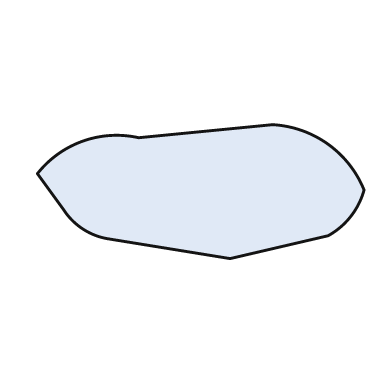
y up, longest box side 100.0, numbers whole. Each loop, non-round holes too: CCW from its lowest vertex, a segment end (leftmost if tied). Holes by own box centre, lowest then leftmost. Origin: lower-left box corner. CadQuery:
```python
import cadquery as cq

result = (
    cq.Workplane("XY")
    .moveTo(59.0, 0.0)
    .lineTo(89.0, 7.0)
    .threePointArc((96.0, 13.0), (100.0, 21.0))
    .threePointArc((89.0, 35.0), (72.0, 41.0))
    .lineTo(31.0, 37.0)
    .threePointArc((14.0, 36.0), (0.0, 26.0))
    .lineTo(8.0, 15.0)
    .threePointArc((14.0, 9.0), (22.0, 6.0))
    .close()
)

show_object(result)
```